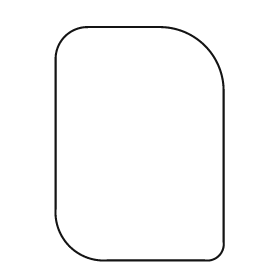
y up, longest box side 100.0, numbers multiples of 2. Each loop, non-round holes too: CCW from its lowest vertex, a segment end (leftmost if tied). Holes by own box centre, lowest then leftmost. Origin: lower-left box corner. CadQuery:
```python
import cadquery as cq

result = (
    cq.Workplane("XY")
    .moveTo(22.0, 0.0)
    .lineTo(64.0, 0.0)
    .threePointArc((70.0, 2.0), (72.0, 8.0))
    .lineTo(72.0, 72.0)
    .threePointArc((64.0, 92.0), (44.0, 100.0))
    .lineTo(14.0, 100.0)
    .threePointArc((4.0, 96.0), (0.0, 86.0))
    .lineTo(0.0, 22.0)
    .threePointArc((6.0, 6.0), (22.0, 0.0))
    .close()
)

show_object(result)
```